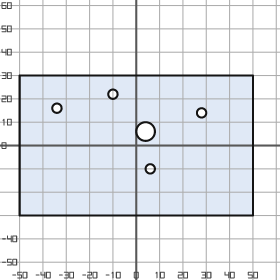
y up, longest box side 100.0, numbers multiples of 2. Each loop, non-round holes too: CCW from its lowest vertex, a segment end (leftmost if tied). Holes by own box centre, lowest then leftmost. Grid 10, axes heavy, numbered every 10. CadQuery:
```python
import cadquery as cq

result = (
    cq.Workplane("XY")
    .moveTo(-50.0, -30.0)
    .lineTo(50.0, -30.0)
    .lineTo(50.0, 30.0)
    .lineTo(-50.0, 30.0)
    .close()
    .moveTo(6.0, -10.0)
    .circle(2.0)
    .moveTo(4.0, 6.0)
    .circle(4.0)
    .moveTo(28.0, 14.0)
    .circle(2.0)
    .moveTo(-34.0, 16.0)
    .circle(2.0)
    .moveTo(-10.0, 22.0)
    .circle(2.0)
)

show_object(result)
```